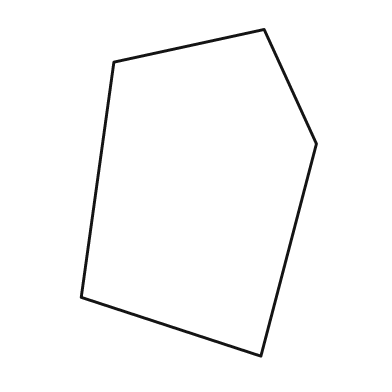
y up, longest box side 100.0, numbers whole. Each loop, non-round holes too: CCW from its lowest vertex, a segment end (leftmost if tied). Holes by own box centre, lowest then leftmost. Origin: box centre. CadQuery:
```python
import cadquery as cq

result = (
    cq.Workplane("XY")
    .moveTo(19.0, -50.0)
    .lineTo(36.0, 15.0)
    .lineTo(20.0, 50.0)
    .lineTo(-26.0, 40.0)
    .lineTo(-36.0, -32.0)
    .close()
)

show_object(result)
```